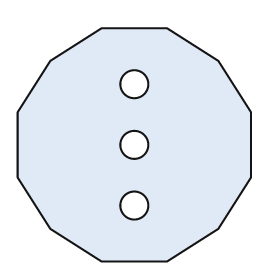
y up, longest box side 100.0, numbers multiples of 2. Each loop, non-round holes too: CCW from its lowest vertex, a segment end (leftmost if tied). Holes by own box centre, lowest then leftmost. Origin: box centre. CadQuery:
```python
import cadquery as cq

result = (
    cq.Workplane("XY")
    .moveTo(-14.0, -50.0)
    .lineTo(14.0, -50.0)
    .lineTo(36.0, -36.0)
    .lineTo(50.0, -14.0)
    .lineTo(50.0, 14.0)
    .lineTo(36.0, 36.0)
    .lineTo(14.0, 50.0)
    .lineTo(-14.0, 50.0)
    .lineTo(-36.0, 36.0)
    .lineTo(-50.0, 14.0)
    .lineTo(-50.0, -14.0)
    .lineTo(-36.0, -36.0)
    .close()
    .moveTo(0.0, -26.0)
    .circle(6.0)
    .moveTo(0.0, 0.0)
    .circle(6.0)
    .moveTo(0.0, 26.0)
    .circle(6.0)
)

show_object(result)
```